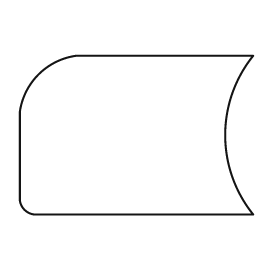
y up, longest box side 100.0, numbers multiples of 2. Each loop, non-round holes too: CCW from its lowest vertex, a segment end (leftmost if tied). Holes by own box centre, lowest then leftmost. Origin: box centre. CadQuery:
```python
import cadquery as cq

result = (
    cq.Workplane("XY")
    .moveTo(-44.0, -34.0)
    .lineTo(50.0, -34.0)
    .threePointArc((38.0, 0.0), (50.0, 34.0))
    .lineTo(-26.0, 34.0)
    .threePointArc((-42.0, 26.0), (-50.0, 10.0))
    .lineTo(-50.0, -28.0)
    .threePointArc((-48.0, -32.0), (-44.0, -34.0))
    .close()
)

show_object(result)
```